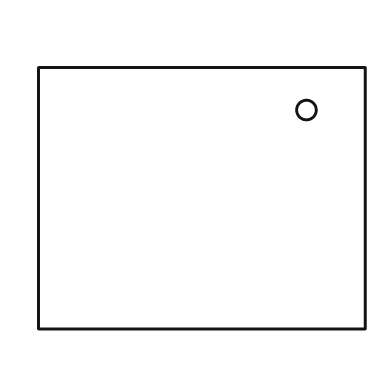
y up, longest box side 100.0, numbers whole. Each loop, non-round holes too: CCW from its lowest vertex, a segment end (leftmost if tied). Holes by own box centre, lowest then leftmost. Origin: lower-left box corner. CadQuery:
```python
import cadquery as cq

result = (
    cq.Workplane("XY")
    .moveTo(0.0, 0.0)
    .lineTo(100.0, 0.0)
    .lineTo(100.0, 80.0)
    .lineTo(0.0, 80.0)
    .close()
    .moveTo(82.0, 67.0)
    .circle(3.0)
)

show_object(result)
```